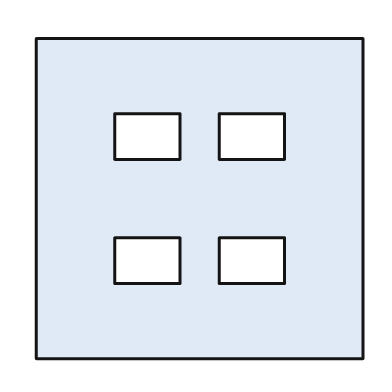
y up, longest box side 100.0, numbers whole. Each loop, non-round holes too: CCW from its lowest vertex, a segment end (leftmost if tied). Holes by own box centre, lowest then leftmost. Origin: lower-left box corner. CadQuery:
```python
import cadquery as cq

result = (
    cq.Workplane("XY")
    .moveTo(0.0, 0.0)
    .lineTo(100.0, 0.0)
    .lineTo(100.0, 98.0)
    .lineTo(0.0, 98.0)
    .close()
    .moveTo(24.0, 23.0)
    .lineTo(44.0, 23.0)
    .lineTo(44.0, 37.0)
    .lineTo(24.0, 37.0)
    .close()
    .moveTo(56.0, 23.0)
    .lineTo(76.0, 23.0)
    .lineTo(76.0, 37.0)
    .lineTo(56.0, 37.0)
    .close()
    .moveTo(24.0, 61.0)
    .lineTo(44.0, 61.0)
    .lineTo(44.0, 75.0)
    .lineTo(24.0, 75.0)
    .close()
    .moveTo(56.0, 61.0)
    .lineTo(76.0, 61.0)
    .lineTo(76.0, 75.0)
    .lineTo(56.0, 75.0)
    .close()
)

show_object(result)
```